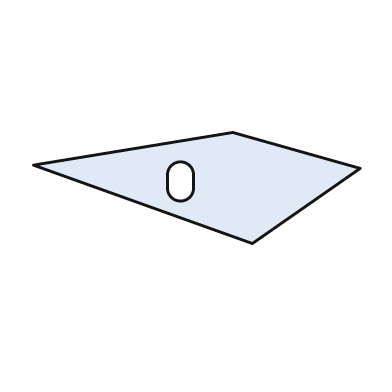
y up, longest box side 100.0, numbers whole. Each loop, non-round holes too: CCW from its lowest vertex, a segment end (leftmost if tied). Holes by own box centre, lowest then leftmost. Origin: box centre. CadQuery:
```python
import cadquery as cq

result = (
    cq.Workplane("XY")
    .moveTo(17.0, -17.0)
    .lineTo(50.0, 6.0)
    .lineTo(11.0, 17.0)
    .lineTo(-50.0, 7.0)
    .close()
    .moveTo(-9.0, 0.0)
    .threePointArc((-5.0, -4.0), (-1.0, 0.0))
    .lineTo(-1.0, 4.0)
    .threePointArc((-5.0, 8.0), (-9.0, 4.0))
    .close()
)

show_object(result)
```